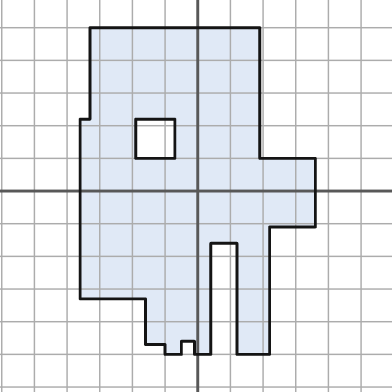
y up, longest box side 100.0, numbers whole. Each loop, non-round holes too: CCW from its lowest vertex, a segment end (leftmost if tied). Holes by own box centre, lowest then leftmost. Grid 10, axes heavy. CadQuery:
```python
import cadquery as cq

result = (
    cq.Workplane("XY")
    .moveTo(-10.0, -50.0)
    .lineTo(-5.0, -50.0)
    .lineTo(-5.0, -46.0)
    .lineTo(-1.0, -46.0)
    .lineTo(-1.0, -50.0)
    .lineTo(4.0, -50.0)
    .lineTo(4.0, -16.0)
    .lineTo(12.0, -16.0)
    .lineTo(12.0, -50.0)
    .lineTo(22.0, -50.0)
    .lineTo(22.0, -11.0)
    .lineTo(36.0, -11.0)
    .lineTo(36.0, 10.0)
    .lineTo(19.0, 10.0)
    .lineTo(19.0, 50.0)
    .lineTo(-33.0, 50.0)
    .lineTo(-33.0, 22.0)
    .lineTo(-36.0, 22.0)
    .lineTo(-36.0, -33.0)
    .lineTo(-16.0, -33.0)
    .lineTo(-16.0, -47.0)
    .lineTo(-10.0, -47.0)
    .close()
    .moveTo(-19.0, 10.0)
    .lineTo(-7.0, 10.0)
    .lineTo(-7.0, 22.0)
    .lineTo(-19.0, 22.0)
    .close()
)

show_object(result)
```